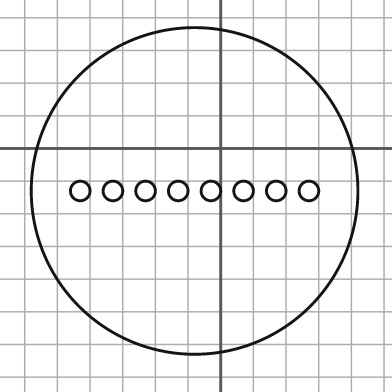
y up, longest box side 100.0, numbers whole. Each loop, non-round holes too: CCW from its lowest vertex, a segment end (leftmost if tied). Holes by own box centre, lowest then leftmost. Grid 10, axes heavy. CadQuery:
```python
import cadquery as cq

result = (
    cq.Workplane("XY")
    .moveTo(-8.0, -13.0)
    .circle(50.0)
    .moveTo(-43.0, -13.0)
    .circle(3.0)
    .moveTo(-33.0, -13.0)
    .circle(3.0)
    .moveTo(-23.0, -13.0)
    .circle(3.0)
    .moveTo(-13.0, -13.0)
    .circle(3.0)
    .moveTo(-3.0, -13.0)
    .circle(3.0)
    .moveTo(7.0, -13.0)
    .circle(3.0)
    .moveTo(17.0, -13.0)
    .circle(3.0)
    .moveTo(27.0, -13.0)
    .circle(3.0)
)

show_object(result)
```